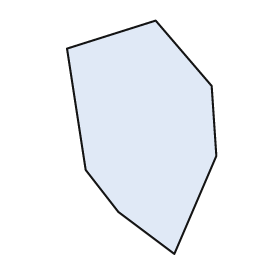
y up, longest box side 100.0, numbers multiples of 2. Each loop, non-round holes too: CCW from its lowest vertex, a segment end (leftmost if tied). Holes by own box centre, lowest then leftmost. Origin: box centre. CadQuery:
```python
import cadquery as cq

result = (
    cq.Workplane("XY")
    .moveTo(14.0, -50.0)
    .lineTo(32.0, -8.0)
    .lineTo(30.0, 22.0)
    .lineTo(6.0, 50.0)
    .lineTo(-32.0, 38.0)
    .lineTo(-24.0, -14.0)
    .lineTo(-10.0, -32.0)
    .close()
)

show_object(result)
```